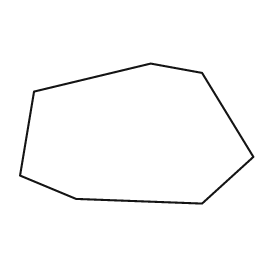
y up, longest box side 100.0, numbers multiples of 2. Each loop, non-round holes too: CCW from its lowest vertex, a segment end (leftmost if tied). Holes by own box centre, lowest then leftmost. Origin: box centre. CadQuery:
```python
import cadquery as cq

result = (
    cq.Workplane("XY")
    .moveTo(28.0, -30.0)
    .lineTo(50.0, -10.0)
    .lineTo(28.0, 26.0)
    .lineTo(6.0, 30.0)
    .lineTo(-44.0, 18.0)
    .lineTo(-50.0, -18.0)
    .lineTo(-26.0, -28.0)
    .close()
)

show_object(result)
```